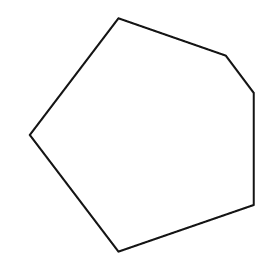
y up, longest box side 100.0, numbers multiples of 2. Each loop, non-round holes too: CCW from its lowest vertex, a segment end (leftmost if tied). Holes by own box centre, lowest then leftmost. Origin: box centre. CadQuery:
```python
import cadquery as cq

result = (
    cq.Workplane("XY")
    .moveTo(-10.0, -50.0)
    .lineTo(48.0, -30.0)
    .lineTo(48.0, 18.0)
    .lineTo(36.0, 34.0)
    .lineTo(-10.0, 50.0)
    .lineTo(-48.0, 0.0)
    .close()
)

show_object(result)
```